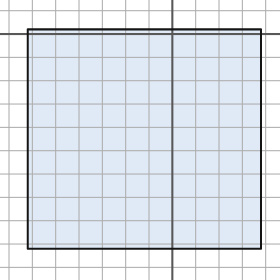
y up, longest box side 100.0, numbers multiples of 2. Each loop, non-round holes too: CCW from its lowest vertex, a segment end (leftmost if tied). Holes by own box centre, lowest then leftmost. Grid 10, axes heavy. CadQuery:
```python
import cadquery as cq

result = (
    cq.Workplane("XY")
    .moveTo(-62.0, -92.0)
    .lineTo(38.0, -92.0)
    .lineTo(38.0, 2.0)
    .lineTo(-62.0, 2.0)
    .close()
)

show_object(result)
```